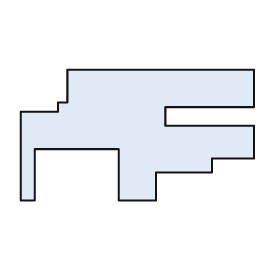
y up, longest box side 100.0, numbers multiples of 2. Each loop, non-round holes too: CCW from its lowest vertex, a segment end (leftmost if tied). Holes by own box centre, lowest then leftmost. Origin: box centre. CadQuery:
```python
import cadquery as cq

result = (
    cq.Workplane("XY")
    .moveTo(-50.0, -28.0)
    .lineTo(-44.0, -28.0)
    .lineTo(-44.0, -6.0)
    .lineTo(-8.0, -6.0)
    .lineTo(-8.0, -28.0)
    .lineTo(8.0, -28.0)
    .lineTo(8.0, -16.0)
    .lineTo(32.0, -16.0)
    .lineTo(32.0, -10.0)
    .lineTo(50.0, -10.0)
    .lineTo(50.0, 4.0)
    .lineTo(12.0, 4.0)
    .lineTo(12.0, 12.0)
    .lineTo(50.0, 12.0)
    .lineTo(50.0, 28.0)
    .lineTo(-30.0, 28.0)
    .lineTo(-30.0, 14.0)
    .lineTo(-34.0, 14.0)
    .lineTo(-34.0, 10.0)
    .lineTo(-50.0, 10.0)
    .close()
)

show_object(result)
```